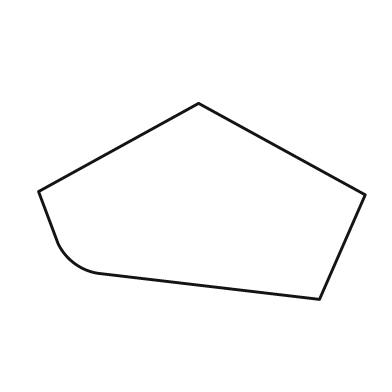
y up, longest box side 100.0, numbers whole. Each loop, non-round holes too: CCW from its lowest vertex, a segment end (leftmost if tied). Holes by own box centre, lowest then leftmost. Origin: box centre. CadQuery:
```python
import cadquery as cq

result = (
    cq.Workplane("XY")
    .moveTo(36.0, -30.0)
    .lineTo(50.0, 2.0)
    .lineTo(-1.0, 30.0)
    .lineTo(-50.0, 3.0)
    .lineTo(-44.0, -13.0)
    .threePointArc((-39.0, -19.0), (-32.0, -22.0))
    .close()
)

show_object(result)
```